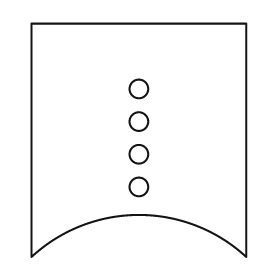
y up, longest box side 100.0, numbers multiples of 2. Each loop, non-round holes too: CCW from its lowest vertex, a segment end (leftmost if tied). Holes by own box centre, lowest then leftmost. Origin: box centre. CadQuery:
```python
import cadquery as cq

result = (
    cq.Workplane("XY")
    .moveTo(-46.0, -50.0)
    .threePointArc((0.0, -32.0), (46.0, -50.0))
    .lineTo(46.0, 50.0)
    .lineTo(-46.0, 50.0)
    .close()
    .moveTo(0.0, -20.0)
    .circle(4.0)
    .moveTo(0.0, -6.0)
    .circle(4.0)
    .moveTo(0.0, 8.0)
    .circle(4.0)
    .moveTo(0.0, 22.0)
    .circle(4.0)
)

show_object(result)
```